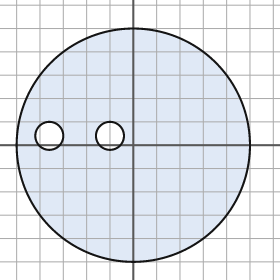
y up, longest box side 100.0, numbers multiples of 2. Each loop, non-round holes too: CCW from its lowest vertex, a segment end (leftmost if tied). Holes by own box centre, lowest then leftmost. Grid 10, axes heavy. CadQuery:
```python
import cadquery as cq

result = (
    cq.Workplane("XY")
    .moveTo(0.0, 0.0)
    .circle(50.0)
    .moveTo(-36.0, 4.0)
    .circle(6.0)
    .moveTo(-10.0, 4.0)
    .circle(6.0)
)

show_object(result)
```